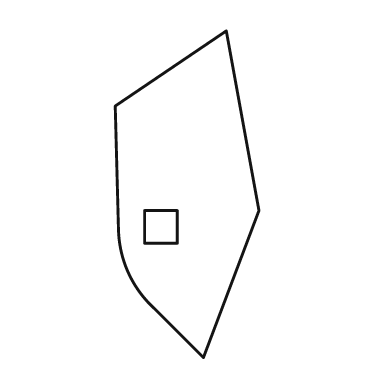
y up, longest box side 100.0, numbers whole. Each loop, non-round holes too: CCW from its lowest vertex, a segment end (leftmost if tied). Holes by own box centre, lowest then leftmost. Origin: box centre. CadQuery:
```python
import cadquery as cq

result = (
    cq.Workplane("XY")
    .moveTo(5.0, -50.0)
    .lineTo(22.0, -5.0)
    .lineTo(12.0, 50.0)
    .lineTo(-22.0, 27.0)
    .lineTo(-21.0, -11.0)
    .threePointArc((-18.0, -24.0), (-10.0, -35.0))
    .close()
    .moveTo(-13.0, -15.0)
    .lineTo(-3.0, -15.0)
    .lineTo(-3.0, -5.0)
    .lineTo(-13.0, -5.0)
    .close()
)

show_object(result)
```